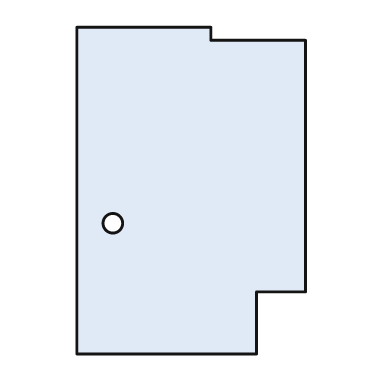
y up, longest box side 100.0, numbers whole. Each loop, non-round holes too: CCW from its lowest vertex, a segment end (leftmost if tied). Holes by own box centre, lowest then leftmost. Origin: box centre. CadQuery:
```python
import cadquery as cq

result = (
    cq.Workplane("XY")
    .moveTo(-35.0, -50.0)
    .lineTo(20.0, -50.0)
    .lineTo(20.0, -31.0)
    .lineTo(35.0, -31.0)
    .lineTo(35.0, 46.0)
    .lineTo(6.0, 46.0)
    .lineTo(6.0, 50.0)
    .lineTo(-35.0, 50.0)
    .close()
    .moveTo(-24.0, -10.0)
    .circle(3.0)
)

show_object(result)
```